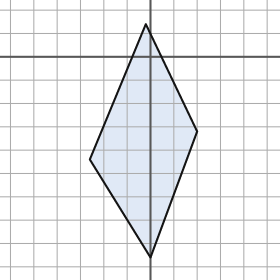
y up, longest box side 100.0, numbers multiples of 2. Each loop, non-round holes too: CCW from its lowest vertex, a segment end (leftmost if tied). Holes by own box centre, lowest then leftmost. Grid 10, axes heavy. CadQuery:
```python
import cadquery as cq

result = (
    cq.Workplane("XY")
    .moveTo(0.0, -86.0)
    .lineTo(20.0, -32.0)
    .lineTo(-2.0, 14.0)
    .lineTo(-26.0, -44.0)
    .close()
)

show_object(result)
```